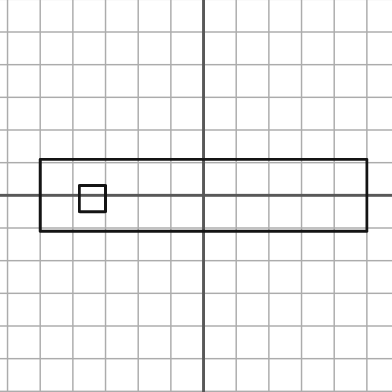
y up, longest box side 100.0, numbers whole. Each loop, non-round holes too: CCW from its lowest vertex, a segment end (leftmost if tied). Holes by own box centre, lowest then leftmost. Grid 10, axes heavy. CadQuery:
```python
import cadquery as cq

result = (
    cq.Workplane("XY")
    .moveTo(-50.0, -11.0)
    .lineTo(50.0, -11.0)
    .lineTo(50.0, 11.0)
    .lineTo(-50.0, 11.0)
    .close()
    .moveTo(-38.0, -5.0)
    .lineTo(-30.0, -5.0)
    .lineTo(-30.0, 3.0)
    .lineTo(-38.0, 3.0)
    .close()
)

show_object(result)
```